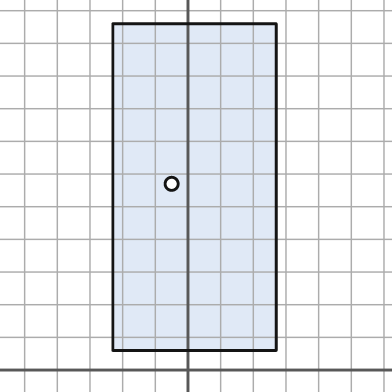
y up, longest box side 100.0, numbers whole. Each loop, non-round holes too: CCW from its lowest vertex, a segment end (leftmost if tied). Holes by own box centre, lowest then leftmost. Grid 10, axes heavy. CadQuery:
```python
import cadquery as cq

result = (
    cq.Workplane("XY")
    .moveTo(-23.0, 6.0)
    .lineTo(27.0, 6.0)
    .lineTo(27.0, 106.0)
    .lineTo(-23.0, 106.0)
    .close()
    .moveTo(-5.0, 57.0)
    .circle(2.0)
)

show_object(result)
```